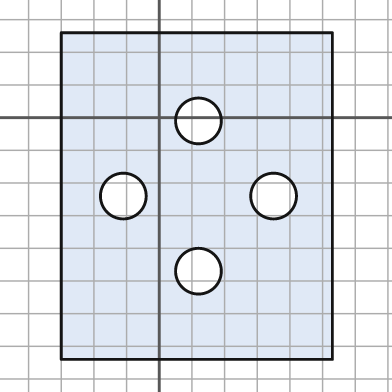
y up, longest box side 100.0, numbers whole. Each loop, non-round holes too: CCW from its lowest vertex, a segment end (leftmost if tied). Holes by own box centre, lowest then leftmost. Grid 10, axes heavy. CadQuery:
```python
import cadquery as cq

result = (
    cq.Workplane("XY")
    .moveTo(-30.0, -74.0)
    .lineTo(53.0, -74.0)
    .lineTo(53.0, 26.0)
    .lineTo(-30.0, 26.0)
    .close()
    .moveTo(12.0, -47.0)
    .circle(7.0)
    .moveTo(-11.0, -24.0)
    .circle(7.0)
    .moveTo(35.0, -24.0)
    .circle(7.0)
    .moveTo(12.0, -1.0)
    .circle(7.0)
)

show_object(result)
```